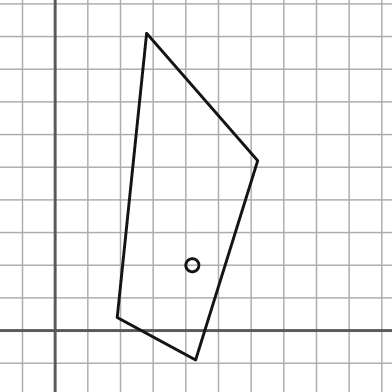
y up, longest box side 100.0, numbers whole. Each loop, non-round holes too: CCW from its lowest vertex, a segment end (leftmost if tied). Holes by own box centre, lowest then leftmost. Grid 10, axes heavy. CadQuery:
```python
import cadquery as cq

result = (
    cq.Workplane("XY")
    .moveTo(43.0, -9.0)
    .lineTo(62.0, 52.0)
    .lineTo(28.0, 91.0)
    .lineTo(19.0, 4.0)
    .close()
    .moveTo(42.0, 20.0)
    .circle(2.0)
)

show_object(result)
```